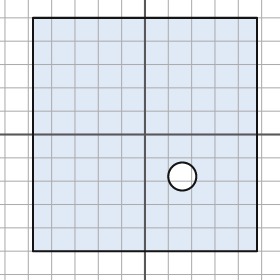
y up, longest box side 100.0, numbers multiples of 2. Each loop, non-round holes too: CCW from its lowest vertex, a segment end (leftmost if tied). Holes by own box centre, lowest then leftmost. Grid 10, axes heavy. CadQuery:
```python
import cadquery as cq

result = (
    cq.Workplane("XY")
    .moveTo(-48.0, -50.0)
    .lineTo(48.0, -50.0)
    .lineTo(48.0, 50.0)
    .lineTo(-48.0, 50.0)
    .close()
    .moveTo(16.0, -18.0)
    .circle(6.0)
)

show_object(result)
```